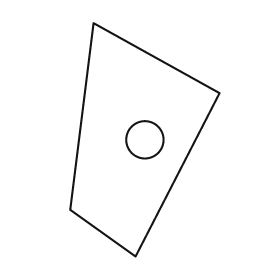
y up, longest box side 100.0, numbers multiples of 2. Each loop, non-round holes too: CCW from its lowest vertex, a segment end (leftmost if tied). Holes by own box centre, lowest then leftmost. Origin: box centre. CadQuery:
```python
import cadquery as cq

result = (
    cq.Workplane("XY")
    .moveTo(-4.0, -50.0)
    .lineTo(32.0, 20.0)
    .lineTo(-22.0, 50.0)
    .lineTo(-32.0, -30.0)
    .close()
    .moveTo(0.0, 0.0)
    .circle(8.0)
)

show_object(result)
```